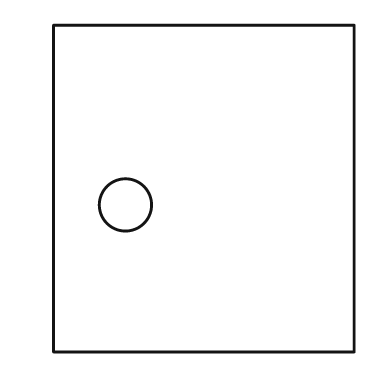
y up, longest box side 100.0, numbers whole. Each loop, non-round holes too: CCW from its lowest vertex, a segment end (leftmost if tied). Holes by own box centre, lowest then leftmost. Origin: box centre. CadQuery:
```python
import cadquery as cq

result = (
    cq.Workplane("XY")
    .moveTo(-46.0, -50.0)
    .lineTo(46.0, -50.0)
    .lineTo(46.0, 50.0)
    .lineTo(-46.0, 50.0)
    .close()
    .moveTo(-24.0, -5.0)
    .circle(8.0)
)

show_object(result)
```